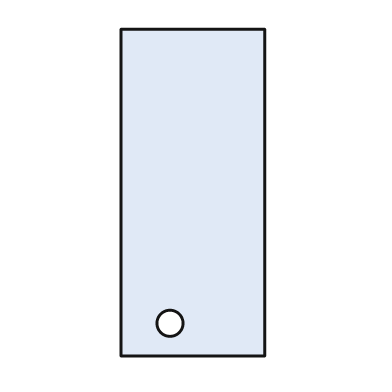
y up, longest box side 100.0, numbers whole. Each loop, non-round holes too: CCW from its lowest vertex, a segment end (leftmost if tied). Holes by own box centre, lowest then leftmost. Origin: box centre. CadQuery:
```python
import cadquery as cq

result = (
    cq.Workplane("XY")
    .moveTo(-22.0, -50.0)
    .lineTo(22.0, -50.0)
    .lineTo(22.0, 50.0)
    .lineTo(-22.0, 50.0)
    .close()
    .moveTo(-7.0, -40.0)
    .circle(4.0)
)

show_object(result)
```